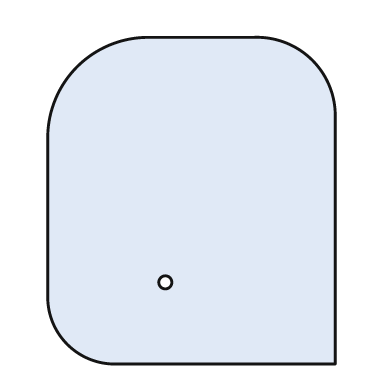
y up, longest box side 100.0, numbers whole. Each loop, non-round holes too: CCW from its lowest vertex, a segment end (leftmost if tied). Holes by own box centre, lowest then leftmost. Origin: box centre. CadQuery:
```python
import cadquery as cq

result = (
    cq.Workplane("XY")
    .moveTo(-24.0, -50.0)
    .lineTo(44.0, -50.0)
    .lineTo(44.0, 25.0)
    .threePointArc((37.0, 43.0), (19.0, 50.0))
    .lineTo(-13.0, 50.0)
    .threePointArc((-35.0, 41.0), (-44.0, 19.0))
    .lineTo(-44.0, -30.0)
    .threePointArc((-38.0, -44.0), (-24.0, -50.0))
    .close()
    .moveTo(-8.0, -25.0)
    .circle(2.0)
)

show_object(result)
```